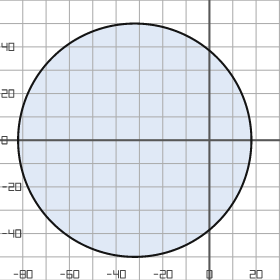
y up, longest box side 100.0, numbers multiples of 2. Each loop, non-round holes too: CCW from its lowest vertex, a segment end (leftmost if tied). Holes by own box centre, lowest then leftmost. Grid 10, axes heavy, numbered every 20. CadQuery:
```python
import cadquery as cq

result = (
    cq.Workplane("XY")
    .moveTo(-32.0, 0.0)
    .circle(50.0)
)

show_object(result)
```